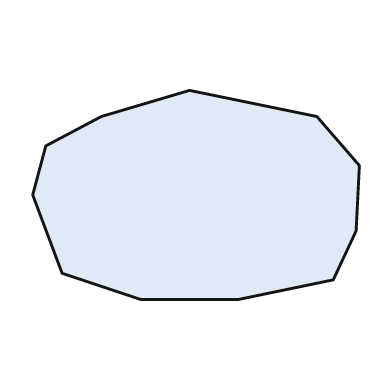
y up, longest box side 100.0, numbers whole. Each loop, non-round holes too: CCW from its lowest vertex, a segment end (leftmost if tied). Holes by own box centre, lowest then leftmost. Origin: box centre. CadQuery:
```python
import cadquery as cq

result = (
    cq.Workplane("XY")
    .moveTo(-17.0, -32.0)
    .lineTo(13.0, -32.0)
    .lineTo(42.0, -26.0)
    .lineTo(49.0, -11.0)
    .lineTo(50.0, 9.0)
    .lineTo(37.0, 24.0)
    .lineTo(-2.0, 32.0)
    .lineTo(-29.0, 24.0)
    .lineTo(-46.0, 15.0)
    .lineTo(-50.0, 0.0)
    .lineTo(-41.0, -24.0)
    .close()
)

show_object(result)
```